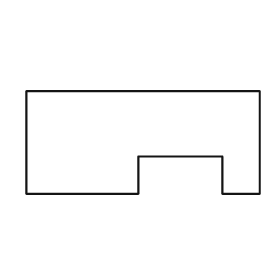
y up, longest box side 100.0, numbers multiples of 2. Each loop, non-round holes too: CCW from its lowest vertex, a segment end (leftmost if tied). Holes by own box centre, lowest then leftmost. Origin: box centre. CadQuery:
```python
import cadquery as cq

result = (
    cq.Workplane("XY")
    .moveTo(-50.0, -22.0)
    .lineTo(-2.0, -22.0)
    .lineTo(-2.0, -6.0)
    .lineTo(34.0, -6.0)
    .lineTo(34.0, -22.0)
    .lineTo(50.0, -22.0)
    .lineTo(50.0, 22.0)
    .lineTo(-50.0, 22.0)
    .close()
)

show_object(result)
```